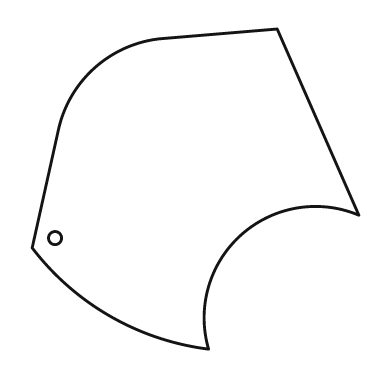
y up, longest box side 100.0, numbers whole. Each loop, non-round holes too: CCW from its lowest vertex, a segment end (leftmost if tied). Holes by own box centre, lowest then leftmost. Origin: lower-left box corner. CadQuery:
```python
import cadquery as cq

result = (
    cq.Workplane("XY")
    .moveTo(54.0, 0.0)
    .threePointArc((64.0, 35.0), (100.0, 41.0))
    .lineTo(75.0, 98.0)
    .lineTo(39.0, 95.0)
    .threePointArc((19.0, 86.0), (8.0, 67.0))
    .lineTo(0.0, 31.0)
    .threePointArc((24.0, 10.0), (54.0, 0.0))
    .close()
    .moveTo(7.0, 34.0)
    .circle(2.0)
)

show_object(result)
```